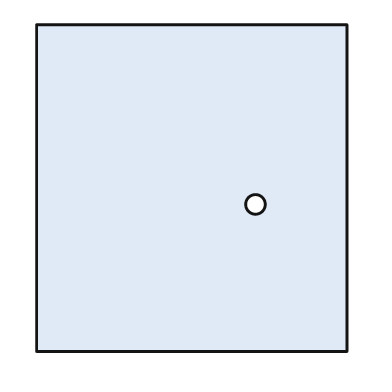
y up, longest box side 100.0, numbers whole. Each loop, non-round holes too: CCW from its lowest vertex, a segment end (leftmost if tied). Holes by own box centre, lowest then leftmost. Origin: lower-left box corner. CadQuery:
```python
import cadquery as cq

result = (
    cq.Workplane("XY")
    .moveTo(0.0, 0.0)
    .lineTo(95.0, 0.0)
    .lineTo(95.0, 100.0)
    .lineTo(0.0, 100.0)
    .close()
    .moveTo(67.0, 45.0)
    .circle(3.0)
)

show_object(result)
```